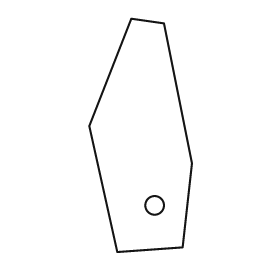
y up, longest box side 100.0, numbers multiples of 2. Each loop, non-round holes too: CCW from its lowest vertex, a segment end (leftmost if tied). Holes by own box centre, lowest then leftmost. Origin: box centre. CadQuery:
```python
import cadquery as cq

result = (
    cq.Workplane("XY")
    .moveTo(-10.0, -50.0)
    .lineTo(18.0, -48.0)
    .lineTo(22.0, -12.0)
    .lineTo(10.0, 48.0)
    .lineTo(-4.0, 50.0)
    .lineTo(-22.0, 4.0)
    .close()
    .moveTo(6.0, -30.0)
    .circle(4.0)
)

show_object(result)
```